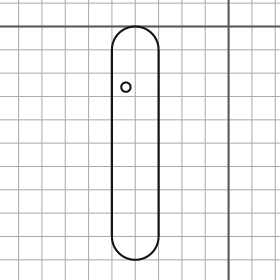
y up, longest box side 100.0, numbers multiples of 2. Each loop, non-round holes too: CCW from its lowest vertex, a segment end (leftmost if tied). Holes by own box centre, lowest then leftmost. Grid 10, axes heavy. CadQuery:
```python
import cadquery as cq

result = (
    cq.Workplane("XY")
    .moveTo(-50.0, -90.0)
    .threePointArc((-40.0, -100.0), (-30.0, -90.0))
    .lineTo(-30.0, -10.0)
    .threePointArc((-40.0, 0.0), (-50.0, -10.0))
    .close()
    .moveTo(-44.0, -26.0)
    .circle(2.0)
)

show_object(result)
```